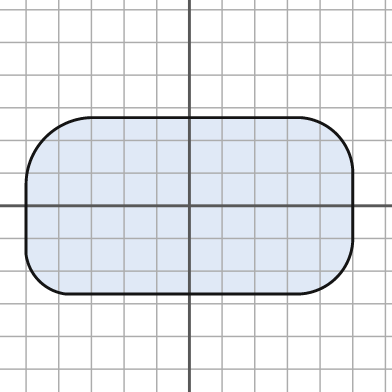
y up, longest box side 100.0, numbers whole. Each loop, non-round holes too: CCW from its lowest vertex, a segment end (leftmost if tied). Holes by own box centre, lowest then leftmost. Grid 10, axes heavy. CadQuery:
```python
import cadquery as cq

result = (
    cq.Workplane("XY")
    .moveTo(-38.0, -27.0)
    .lineTo(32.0, -27.0)
    .threePointArc((45.0, -22.0), (50.0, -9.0))
    .lineTo(50.0, 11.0)
    .threePointArc((45.0, 22.0), (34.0, 27.0))
    .lineTo(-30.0, 27.0)
    .threePointArc((-44.0, 21.0), (-50.0, 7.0))
    .lineTo(-50.0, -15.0)
    .threePointArc((-46.0, -23.0), (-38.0, -27.0))
    .close()
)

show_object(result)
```